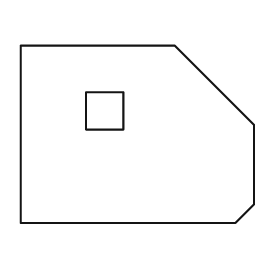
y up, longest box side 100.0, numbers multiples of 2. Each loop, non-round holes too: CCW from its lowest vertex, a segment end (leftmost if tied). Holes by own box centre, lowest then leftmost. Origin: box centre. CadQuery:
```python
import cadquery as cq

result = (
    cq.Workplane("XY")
    .moveTo(-50.0, -38.0)
    .lineTo(42.0, -38.0)
    .lineTo(50.0, -30.0)
    .lineTo(50.0, 4.0)
    .lineTo(16.0, 38.0)
    .lineTo(-50.0, 38.0)
    .close()
    .moveTo(-22.0, 2.0)
    .lineTo(-6.0, 2.0)
    .lineTo(-6.0, 18.0)
    .lineTo(-22.0, 18.0)
    .close()
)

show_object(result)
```